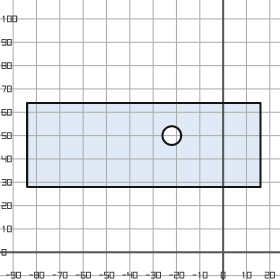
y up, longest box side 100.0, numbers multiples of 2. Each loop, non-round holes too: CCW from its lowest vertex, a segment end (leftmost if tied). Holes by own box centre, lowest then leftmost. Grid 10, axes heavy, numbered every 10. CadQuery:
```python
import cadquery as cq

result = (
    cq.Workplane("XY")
    .moveTo(-84.0, 28.0)
    .lineTo(16.0, 28.0)
    .lineTo(16.0, 64.0)
    .lineTo(-84.0, 64.0)
    .close()
    .moveTo(-22.0, 50.0)
    .circle(4.0)
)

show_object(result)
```